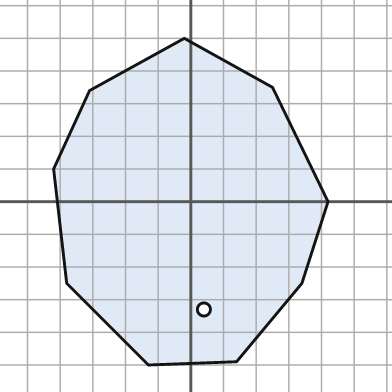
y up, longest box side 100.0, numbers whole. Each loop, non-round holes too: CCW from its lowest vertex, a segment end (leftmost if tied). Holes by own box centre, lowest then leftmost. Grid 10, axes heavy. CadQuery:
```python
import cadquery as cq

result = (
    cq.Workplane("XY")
    .moveTo(-13.0, -50.0)
    .lineTo(14.0, -49.0)
    .lineTo(34.0, -25.0)
    .lineTo(42.0, 0.0)
    .lineTo(25.0, 35.0)
    .lineTo(-2.0, 50.0)
    .lineTo(-31.0, 34.0)
    .lineTo(-42.0, 10.0)
    .lineTo(-38.0, -25.0)
    .close()
    .moveTo(4.0, -33.0)
    .circle(2.0)
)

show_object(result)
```